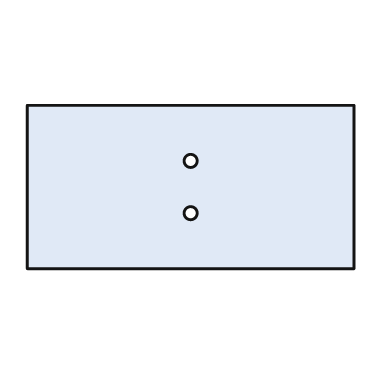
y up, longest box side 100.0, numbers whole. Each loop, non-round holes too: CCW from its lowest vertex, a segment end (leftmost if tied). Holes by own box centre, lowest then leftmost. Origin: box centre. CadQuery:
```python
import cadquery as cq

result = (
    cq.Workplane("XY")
    .moveTo(-50.0, -25.0)
    .lineTo(50.0, -25.0)
    .lineTo(50.0, 25.0)
    .lineTo(-50.0, 25.0)
    .close()
    .moveTo(0.0, -8.0)
    .circle(2.0)
    .moveTo(0.0, 8.0)
    .circle(2.0)
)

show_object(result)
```